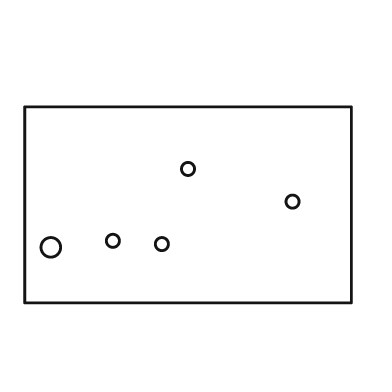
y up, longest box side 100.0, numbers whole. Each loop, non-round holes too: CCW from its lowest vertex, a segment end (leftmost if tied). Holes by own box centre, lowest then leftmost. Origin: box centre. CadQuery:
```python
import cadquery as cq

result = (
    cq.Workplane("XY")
    .moveTo(-50.0, -30.0)
    .lineTo(50.0, -30.0)
    .lineTo(50.0, 30.0)
    .lineTo(-50.0, 30.0)
    .close()
    .moveTo(-42.0, -13.0)
    .circle(3.0)
    .moveTo(-8.0, -12.0)
    .circle(2.0)
    .moveTo(-23.0, -11.0)
    .circle(2.0)
    .moveTo(32.0, 1.0)
    .circle(2.0)
    .moveTo(0.0, 11.0)
    .circle(2.0)
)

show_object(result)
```